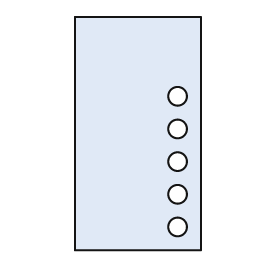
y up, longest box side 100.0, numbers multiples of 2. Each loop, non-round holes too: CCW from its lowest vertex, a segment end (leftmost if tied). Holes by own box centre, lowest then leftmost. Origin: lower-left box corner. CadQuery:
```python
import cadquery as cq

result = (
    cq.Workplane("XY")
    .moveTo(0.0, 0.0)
    .lineTo(54.0, 0.0)
    .lineTo(54.0, 100.0)
    .lineTo(0.0, 100.0)
    .close()
    .moveTo(44.0, 10.0)
    .circle(4.0)
    .moveTo(44.0, 24.0)
    .circle(4.0)
    .moveTo(44.0, 38.0)
    .circle(4.0)
    .moveTo(44.0, 52.0)
    .circle(4.0)
    .moveTo(44.0, 66.0)
    .circle(4.0)
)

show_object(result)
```